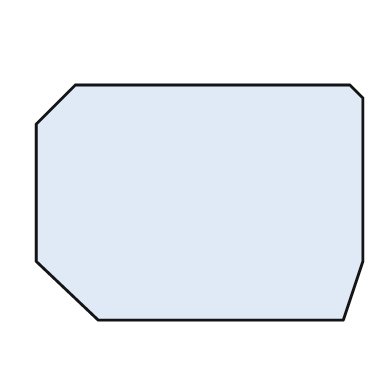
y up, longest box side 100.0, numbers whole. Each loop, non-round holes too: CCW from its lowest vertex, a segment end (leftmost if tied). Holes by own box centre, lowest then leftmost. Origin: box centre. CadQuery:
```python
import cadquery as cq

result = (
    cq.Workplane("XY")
    .moveTo(-31.0, -36.0)
    .lineTo(44.0, -36.0)
    .lineTo(50.0, -18.0)
    .lineTo(50.0, 32.0)
    .lineTo(46.0, 36.0)
    .lineTo(-38.0, 36.0)
    .lineTo(-50.0, 24.0)
    .lineTo(-50.0, -18.0)
    .close()
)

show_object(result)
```